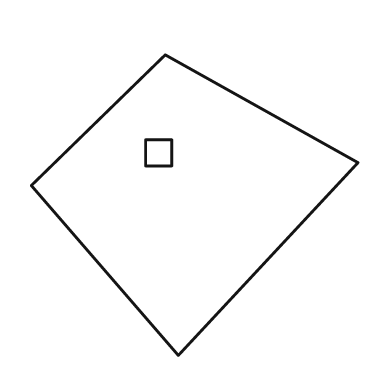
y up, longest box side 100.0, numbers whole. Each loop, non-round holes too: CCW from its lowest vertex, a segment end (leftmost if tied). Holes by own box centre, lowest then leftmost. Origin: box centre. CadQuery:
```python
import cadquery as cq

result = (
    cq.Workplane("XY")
    .moveTo(-5.0, -46.0)
    .lineTo(50.0, 13.0)
    .lineTo(-9.0, 46.0)
    .lineTo(-50.0, 6.0)
    .close()
    .moveTo(-15.0, 12.0)
    .lineTo(-7.0, 12.0)
    .lineTo(-7.0, 20.0)
    .lineTo(-15.0, 20.0)
    .close()
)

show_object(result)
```